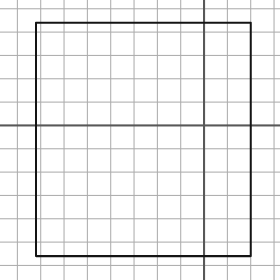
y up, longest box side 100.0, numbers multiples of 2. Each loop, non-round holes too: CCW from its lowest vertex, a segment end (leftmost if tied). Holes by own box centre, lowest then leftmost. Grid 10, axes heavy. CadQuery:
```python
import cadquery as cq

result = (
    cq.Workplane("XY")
    .moveTo(-72.0, -56.0)
    .lineTo(20.0, -56.0)
    .lineTo(20.0, 44.0)
    .lineTo(-72.0, 44.0)
    .close()
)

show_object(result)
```